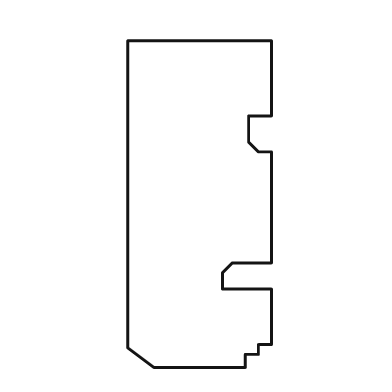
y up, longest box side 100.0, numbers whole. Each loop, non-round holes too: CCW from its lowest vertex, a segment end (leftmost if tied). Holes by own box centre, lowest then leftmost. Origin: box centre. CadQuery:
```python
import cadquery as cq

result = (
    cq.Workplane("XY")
    .moveTo(-14.0, -50.0)
    .lineTo(14.0, -50.0)
    .lineTo(14.0, -46.0)
    .lineTo(18.0, -46.0)
    .lineTo(18.0, -43.0)
    .lineTo(22.0, -43.0)
    .lineTo(22.0, -26.0)
    .lineTo(7.0, -26.0)
    .lineTo(7.0, -21.0)
    .lineTo(10.0, -18.0)
    .lineTo(22.0, -18.0)
    .lineTo(22.0, 16.0)
    .lineTo(18.0, 16.0)
    .lineTo(15.0, 19.0)
    .lineTo(15.0, 27.0)
    .lineTo(22.0, 27.0)
    .lineTo(22.0, 50.0)
    .lineTo(-22.0, 50.0)
    .lineTo(-22.0, -44.0)
    .close()
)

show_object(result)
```